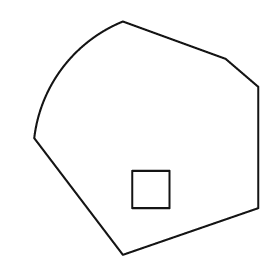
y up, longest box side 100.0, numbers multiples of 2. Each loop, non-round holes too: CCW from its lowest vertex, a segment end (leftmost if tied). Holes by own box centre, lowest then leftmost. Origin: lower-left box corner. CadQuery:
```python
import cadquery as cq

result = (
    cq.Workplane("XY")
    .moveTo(38.0, 0.0)
    .lineTo(96.0, 20.0)
    .lineTo(96.0, 72.0)
    .lineTo(82.0, 84.0)
    .lineTo(38.0, 100.0)
    .threePointArc((12.0, 80.0), (0.0, 50.0))
    .close()
    .moveTo(42.0, 20.0)
    .lineTo(58.0, 20.0)
    .lineTo(58.0, 36.0)
    .lineTo(42.0, 36.0)
    .close()
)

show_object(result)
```